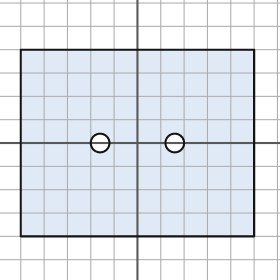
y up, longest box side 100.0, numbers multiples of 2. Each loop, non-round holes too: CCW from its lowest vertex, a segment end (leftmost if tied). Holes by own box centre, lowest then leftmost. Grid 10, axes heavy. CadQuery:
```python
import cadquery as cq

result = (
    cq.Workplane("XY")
    .moveTo(-50.0, -40.0)
    .lineTo(50.0, -40.0)
    .lineTo(50.0, 40.0)
    .lineTo(-50.0, 40.0)
    .close()
    .moveTo(-16.0, 0.0)
    .circle(4.0)
    .moveTo(16.0, 0.0)
    .circle(4.0)
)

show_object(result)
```